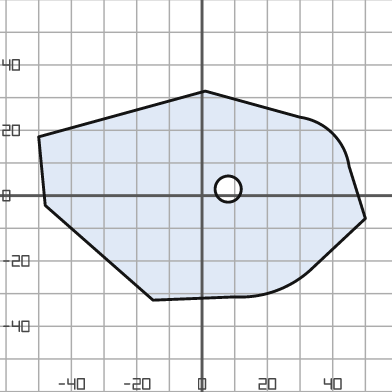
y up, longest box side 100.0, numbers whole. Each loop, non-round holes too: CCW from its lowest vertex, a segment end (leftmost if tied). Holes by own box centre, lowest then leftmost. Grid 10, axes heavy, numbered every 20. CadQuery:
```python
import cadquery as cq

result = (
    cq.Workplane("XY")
    .moveTo(-15.0, -32.0)
    .lineTo(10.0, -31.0)
    .threePointArc((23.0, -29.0), (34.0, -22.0))
    .lineTo(50.0, -7.0)
    .lineTo(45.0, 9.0)
    .threePointArc((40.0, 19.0), (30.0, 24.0))
    .lineTo(1.0, 32.0)
    .lineTo(-50.0, 18.0)
    .lineTo(-48.0, -3.0)
    .close()
    .moveTo(8.0, 2.0)
    .circle(4.0)
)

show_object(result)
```